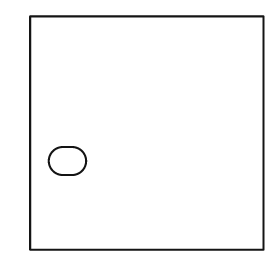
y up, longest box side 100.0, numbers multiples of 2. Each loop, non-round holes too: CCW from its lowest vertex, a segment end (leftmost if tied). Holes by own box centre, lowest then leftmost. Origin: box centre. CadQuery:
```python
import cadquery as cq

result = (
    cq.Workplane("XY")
    .moveTo(-50.0, -50.0)
    .lineTo(50.0, -50.0)
    .lineTo(50.0, 50.0)
    .lineTo(-50.0, 50.0)
    .close()
    .moveTo(-36.0, -18.0)
    .lineTo(-32.0, -18.0)
    .threePointArc((-26.0, -12.0), (-32.0, -6.0))
    .lineTo(-36.0, -6.0)
    .threePointArc((-42.0, -12.0), (-36.0, -18.0))
    .close()
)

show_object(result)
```